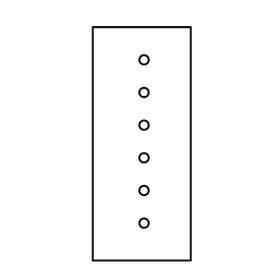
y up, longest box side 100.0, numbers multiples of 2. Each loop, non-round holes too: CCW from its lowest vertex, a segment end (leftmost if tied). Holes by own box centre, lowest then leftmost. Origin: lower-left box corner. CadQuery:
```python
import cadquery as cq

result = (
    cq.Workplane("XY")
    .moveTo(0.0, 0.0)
    .lineTo(42.0, 0.0)
    .lineTo(42.0, 100.0)
    .lineTo(0.0, 100.0)
    .close()
    .moveTo(22.0, 16.0)
    .circle(2.0)
    .moveTo(22.0, 30.0)
    .circle(2.0)
    .moveTo(22.0, 44.0)
    .circle(2.0)
    .moveTo(22.0, 58.0)
    .circle(2.0)
    .moveTo(22.0, 72.0)
    .circle(2.0)
    .moveTo(22.0, 86.0)
    .circle(2.0)
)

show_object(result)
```